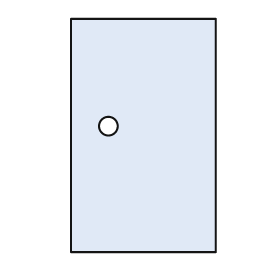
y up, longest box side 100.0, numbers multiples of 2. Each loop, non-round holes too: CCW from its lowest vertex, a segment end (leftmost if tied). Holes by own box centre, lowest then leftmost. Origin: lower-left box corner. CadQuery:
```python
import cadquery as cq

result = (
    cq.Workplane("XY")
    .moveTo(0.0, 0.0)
    .lineTo(62.0, 0.0)
    .lineTo(62.0, 100.0)
    .lineTo(0.0, 100.0)
    .close()
    .moveTo(16.0, 54.0)
    .circle(4.0)
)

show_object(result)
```